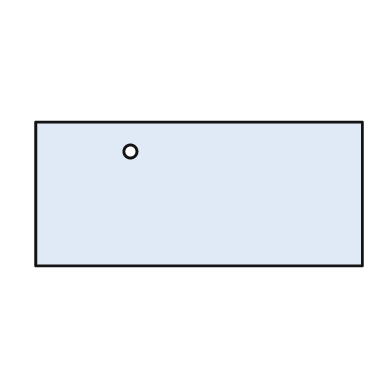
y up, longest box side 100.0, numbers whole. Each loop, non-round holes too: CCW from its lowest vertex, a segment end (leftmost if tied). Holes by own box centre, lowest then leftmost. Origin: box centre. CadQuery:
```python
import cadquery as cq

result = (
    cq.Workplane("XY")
    .moveTo(-50.0, -22.0)
    .lineTo(50.0, -22.0)
    .lineTo(50.0, 22.0)
    .lineTo(-50.0, 22.0)
    .close()
    .moveTo(-21.0, 13.0)
    .circle(2.0)
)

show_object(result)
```